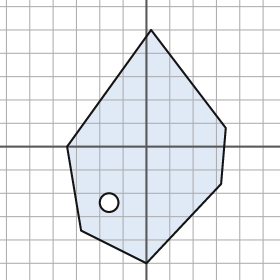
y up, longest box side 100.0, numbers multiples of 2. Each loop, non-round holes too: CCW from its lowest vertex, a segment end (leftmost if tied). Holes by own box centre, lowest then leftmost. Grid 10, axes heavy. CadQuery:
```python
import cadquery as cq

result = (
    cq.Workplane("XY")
    .moveTo(0.0, -50.0)
    .lineTo(32.0, -16.0)
    .lineTo(34.0, 8.0)
    .lineTo(2.0, 50.0)
    .lineTo(-34.0, 0.0)
    .lineTo(-28.0, -36.0)
    .close()
    .moveTo(-16.0, -24.0)
    .circle(4.0)
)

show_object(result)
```